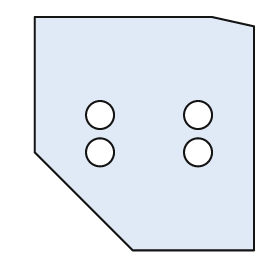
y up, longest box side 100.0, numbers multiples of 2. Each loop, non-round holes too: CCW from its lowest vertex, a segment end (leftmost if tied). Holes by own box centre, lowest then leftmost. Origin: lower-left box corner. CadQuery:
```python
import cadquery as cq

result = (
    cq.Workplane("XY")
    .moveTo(42.0, 0.0)
    .lineTo(94.0, 0.0)
    .lineTo(94.0, 96.0)
    .lineTo(76.0, 100.0)
    .lineTo(0.0, 100.0)
    .lineTo(0.0, 42.0)
    .close()
    .moveTo(28.0, 42.0)
    .circle(6.0)
    .moveTo(70.0, 42.0)
    .circle(6.0)
    .moveTo(28.0, 58.0)
    .circle(6.0)
    .moveTo(70.0, 58.0)
    .circle(6.0)
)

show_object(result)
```